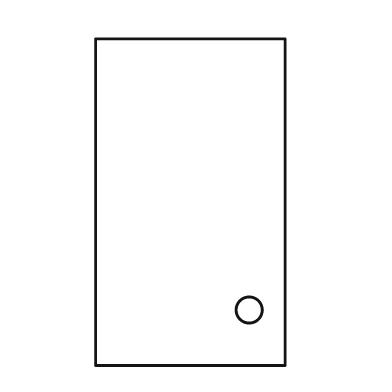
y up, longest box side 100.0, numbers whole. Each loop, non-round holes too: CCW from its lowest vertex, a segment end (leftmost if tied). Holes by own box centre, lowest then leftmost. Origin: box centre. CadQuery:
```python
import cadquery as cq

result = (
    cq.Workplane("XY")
    .moveTo(-29.0, -50.0)
    .lineTo(29.0, -50.0)
    .lineTo(29.0, 50.0)
    .lineTo(-29.0, 50.0)
    .close()
    .moveTo(18.0, -33.0)
    .circle(4.0)
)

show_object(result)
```